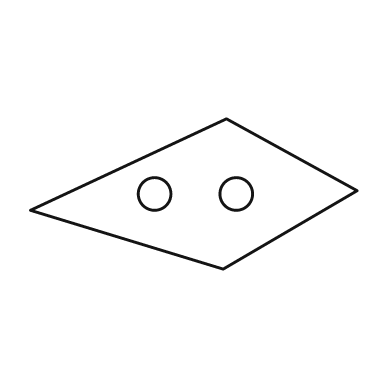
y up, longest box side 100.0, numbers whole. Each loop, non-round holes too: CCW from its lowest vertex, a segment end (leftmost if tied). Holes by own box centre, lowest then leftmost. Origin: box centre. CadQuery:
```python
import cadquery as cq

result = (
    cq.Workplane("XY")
    .moveTo(9.0, -23.0)
    .lineTo(50.0, 1.0)
    .lineTo(10.0, 23.0)
    .lineTo(-50.0, -5.0)
    .close()
    .moveTo(-12.0, 0.0)
    .circle(5.0)
    .moveTo(13.0, 0.0)
    .circle(5.0)
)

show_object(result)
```